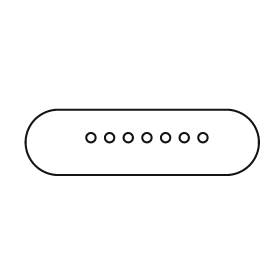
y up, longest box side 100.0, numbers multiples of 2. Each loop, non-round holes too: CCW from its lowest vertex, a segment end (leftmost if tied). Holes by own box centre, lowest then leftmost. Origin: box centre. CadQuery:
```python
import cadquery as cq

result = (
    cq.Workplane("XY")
    .moveTo(-36.0, -14.0)
    .lineTo(36.0, -14.0)
    .threePointArc((50.0, 0.0), (36.0, 14.0))
    .lineTo(-36.0, 14.0)
    .threePointArc((-50.0, 0.0), (-36.0, -14.0))
    .close()
    .moveTo(-22.0, 2.0)
    .circle(2.0)
    .moveTo(-14.0, 2.0)
    .circle(2.0)
    .moveTo(-6.0, 2.0)
    .circle(2.0)
    .moveTo(2.0, 2.0)
    .circle(2.0)
    .moveTo(10.0, 2.0)
    .circle(2.0)
    .moveTo(18.0, 2.0)
    .circle(2.0)
    .moveTo(26.0, 2.0)
    .circle(2.0)
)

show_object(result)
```